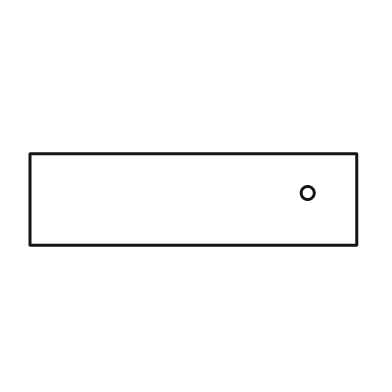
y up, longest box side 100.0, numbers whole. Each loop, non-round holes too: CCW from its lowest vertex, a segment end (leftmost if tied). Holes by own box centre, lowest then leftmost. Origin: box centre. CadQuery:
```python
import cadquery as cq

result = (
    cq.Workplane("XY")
    .moveTo(-50.0, -14.0)
    .lineTo(50.0, -14.0)
    .lineTo(50.0, 14.0)
    .lineTo(-50.0, 14.0)
    .close()
    .moveTo(35.0, 2.0)
    .circle(2.0)
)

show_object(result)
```